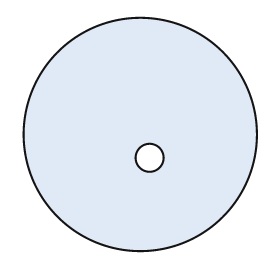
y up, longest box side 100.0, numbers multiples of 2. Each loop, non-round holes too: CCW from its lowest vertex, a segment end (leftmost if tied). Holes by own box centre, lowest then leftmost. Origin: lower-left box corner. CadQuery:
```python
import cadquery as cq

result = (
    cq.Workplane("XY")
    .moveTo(50.0, 50.0)
    .circle(50.0)
    .moveTo(54.0, 40.0)
    .circle(6.0)
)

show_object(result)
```